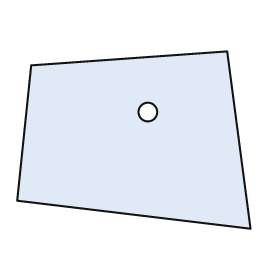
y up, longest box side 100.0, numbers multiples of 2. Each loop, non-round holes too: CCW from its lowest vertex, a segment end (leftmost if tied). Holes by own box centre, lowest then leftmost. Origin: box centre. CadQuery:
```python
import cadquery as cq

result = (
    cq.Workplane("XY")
    .moveTo(50.0, -38.0)
    .lineTo(40.0, 38.0)
    .lineTo(-44.0, 32.0)
    .lineTo(-50.0, -26.0)
    .close()
    .moveTo(6.0, 12.0)
    .circle(4.0)
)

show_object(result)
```